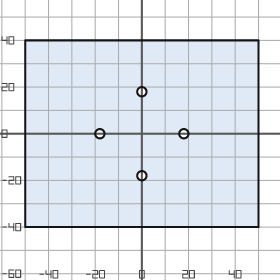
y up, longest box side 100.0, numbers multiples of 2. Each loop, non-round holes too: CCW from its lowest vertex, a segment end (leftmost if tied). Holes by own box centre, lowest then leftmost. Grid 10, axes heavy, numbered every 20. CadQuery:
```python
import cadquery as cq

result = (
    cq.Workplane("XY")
    .moveTo(-50.0, -40.0)
    .lineTo(50.0, -40.0)
    .lineTo(50.0, 40.0)
    .lineTo(-50.0, 40.0)
    .close()
    .moveTo(0.0, -18.0)
    .circle(2.0)
    .moveTo(-18.0, 0.0)
    .circle(2.0)
    .moveTo(18.0, 0.0)
    .circle(2.0)
    .moveTo(0.0, 18.0)
    .circle(2.0)
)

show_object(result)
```